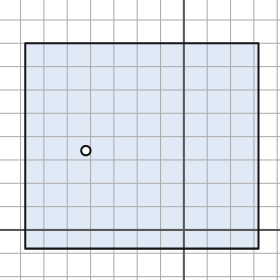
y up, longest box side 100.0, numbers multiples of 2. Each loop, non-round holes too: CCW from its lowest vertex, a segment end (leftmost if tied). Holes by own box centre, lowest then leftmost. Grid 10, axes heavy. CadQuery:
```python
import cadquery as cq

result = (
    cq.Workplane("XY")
    .moveTo(-68.0, -8.0)
    .lineTo(32.0, -8.0)
    .lineTo(32.0, 80.0)
    .lineTo(-68.0, 80.0)
    .close()
    .moveTo(-42.0, 34.0)
    .circle(2.0)
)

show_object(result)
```